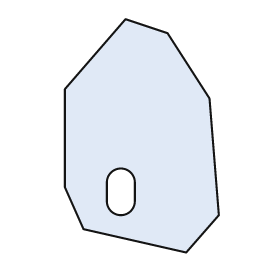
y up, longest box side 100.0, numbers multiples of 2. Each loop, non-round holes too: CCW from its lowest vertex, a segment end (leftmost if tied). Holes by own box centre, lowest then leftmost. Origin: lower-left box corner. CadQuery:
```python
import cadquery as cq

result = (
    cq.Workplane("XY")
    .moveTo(52.0, 0.0)
    .lineTo(66.0, 16.0)
    .lineTo(62.0, 66.0)
    .lineTo(44.0, 94.0)
    .lineTo(26.0, 100.0)
    .lineTo(0.0, 70.0)
    .lineTo(0.0, 28.0)
    .lineTo(8.0, 10.0)
    .close()
    .moveTo(18.0, 22.0)
    .threePointArc((24.0, 16.0), (30.0, 22.0))
    .lineTo(30.0, 30.0)
    .threePointArc((24.0, 36.0), (18.0, 30.0))
    .close()
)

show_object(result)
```